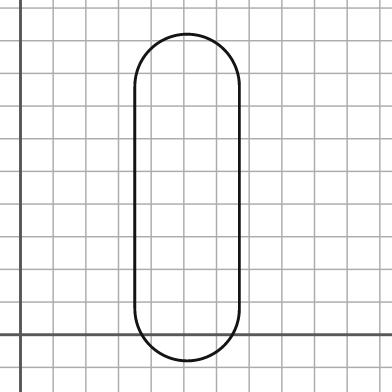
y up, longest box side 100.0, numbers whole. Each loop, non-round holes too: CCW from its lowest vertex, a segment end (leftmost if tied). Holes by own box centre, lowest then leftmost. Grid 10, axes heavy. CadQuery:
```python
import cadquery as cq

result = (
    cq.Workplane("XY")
    .moveTo(35.0, 8.0)
    .threePointArc((51.0, -8.0), (67.0, 8.0))
    .lineTo(67.0, 76.0)
    .threePointArc((51.0, 92.0), (35.0, 76.0))
    .close()
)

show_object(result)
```